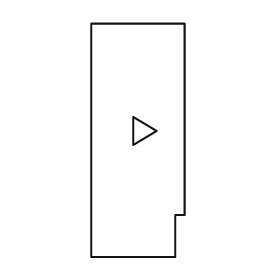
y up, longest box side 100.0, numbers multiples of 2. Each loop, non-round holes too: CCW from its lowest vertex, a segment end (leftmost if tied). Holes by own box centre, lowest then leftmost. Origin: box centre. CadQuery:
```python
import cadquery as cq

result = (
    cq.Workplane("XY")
    .moveTo(-20.0, -50.0)
    .lineTo(16.0, -50.0)
    .lineTo(16.0, -32.0)
    .lineTo(20.0, -32.0)
    .lineTo(20.0, 50.0)
    .lineTo(-20.0, 50.0)
    .close()
    .moveTo(-2.0, -2.0)
    .lineTo(8.0, 4.0)
    .lineTo(-2.0, 10.0)
    .close()
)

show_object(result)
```